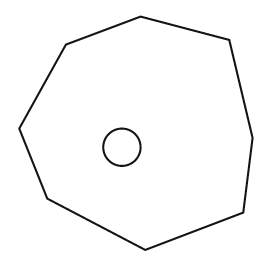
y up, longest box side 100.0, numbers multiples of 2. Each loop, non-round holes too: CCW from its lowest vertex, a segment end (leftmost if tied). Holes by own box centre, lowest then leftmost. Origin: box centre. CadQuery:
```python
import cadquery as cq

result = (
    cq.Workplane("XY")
    .moveTo(4.0, -50.0)
    .lineTo(46.0, -34.0)
    .lineTo(50.0, -2.0)
    .lineTo(40.0, 40.0)
    .lineTo(2.0, 50.0)
    .lineTo(-30.0, 38.0)
    .lineTo(-50.0, 2.0)
    .lineTo(-38.0, -28.0)
    .close()
    .moveTo(-6.0, -6.0)
    .circle(8.0)
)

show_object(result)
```